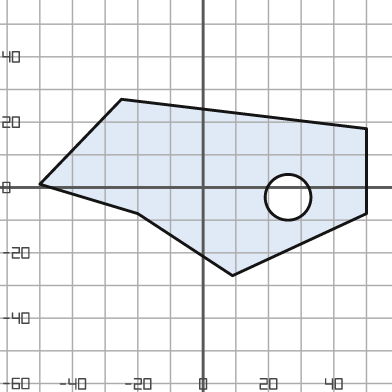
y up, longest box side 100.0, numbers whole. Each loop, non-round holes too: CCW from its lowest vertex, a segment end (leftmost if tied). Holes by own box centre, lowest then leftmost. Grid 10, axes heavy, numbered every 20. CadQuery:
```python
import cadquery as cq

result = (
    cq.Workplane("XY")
    .moveTo(9.0, -27.0)
    .lineTo(50.0, -8.0)
    .lineTo(50.0, 18.0)
    .lineTo(-25.0, 27.0)
    .lineTo(-50.0, 1.0)
    .lineTo(-20.0, -8.0)
    .close()
    .moveTo(26.0, -3.0)
    .circle(7.0)
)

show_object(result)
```